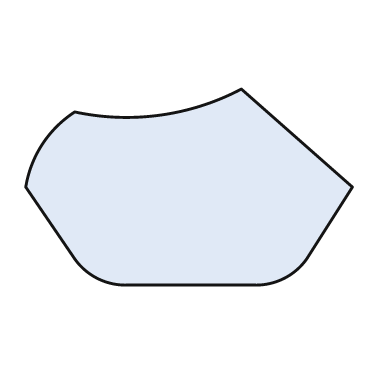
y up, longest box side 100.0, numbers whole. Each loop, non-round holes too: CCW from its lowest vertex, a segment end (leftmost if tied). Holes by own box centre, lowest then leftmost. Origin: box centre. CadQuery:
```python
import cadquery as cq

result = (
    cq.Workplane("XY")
    .moveTo(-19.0, -30.0)
    .lineTo(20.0, -30.0)
    .threePointArc((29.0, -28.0), (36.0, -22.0))
    .lineTo(50.0, 0.0)
    .lineTo(16.0, 30.0)
    .threePointArc((-9.0, 22.0), (-35.0, 23.0))
    .threePointArc((-45.0, 13.0), (-50.0, 0.0))
    .lineTo(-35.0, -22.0)
    .threePointArc((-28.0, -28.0), (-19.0, -30.0))
    .close()
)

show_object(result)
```